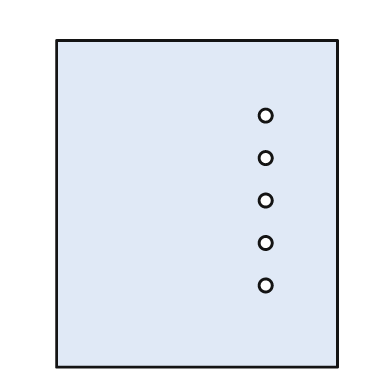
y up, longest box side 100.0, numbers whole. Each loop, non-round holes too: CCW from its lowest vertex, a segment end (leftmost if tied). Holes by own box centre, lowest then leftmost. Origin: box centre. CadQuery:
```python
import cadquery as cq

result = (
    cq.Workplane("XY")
    .moveTo(-43.0, -50.0)
    .lineTo(43.0, -50.0)
    .lineTo(43.0, 50.0)
    .lineTo(-43.0, 50.0)
    .close()
    .moveTo(21.0, -25.0)
    .circle(2.0)
    .moveTo(21.0, -12.0)
    .circle(2.0)
    .moveTo(21.0, 1.0)
    .circle(2.0)
    .moveTo(21.0, 14.0)
    .circle(2.0)
    .moveTo(21.0, 27.0)
    .circle(2.0)
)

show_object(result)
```